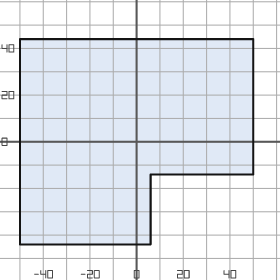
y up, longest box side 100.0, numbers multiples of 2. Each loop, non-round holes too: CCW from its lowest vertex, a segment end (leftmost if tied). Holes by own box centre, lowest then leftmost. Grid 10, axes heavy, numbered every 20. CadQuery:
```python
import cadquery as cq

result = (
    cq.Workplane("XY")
    .moveTo(-50.0, -44.0)
    .lineTo(6.0, -44.0)
    .lineTo(6.0, -14.0)
    .lineTo(50.0, -14.0)
    .lineTo(50.0, 44.0)
    .lineTo(-50.0, 44.0)
    .close()
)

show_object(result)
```